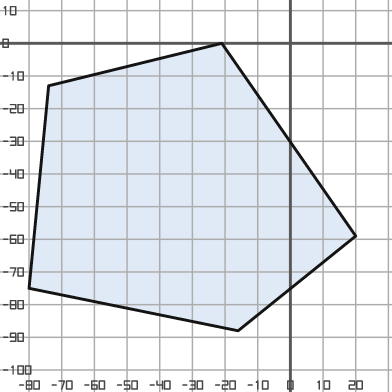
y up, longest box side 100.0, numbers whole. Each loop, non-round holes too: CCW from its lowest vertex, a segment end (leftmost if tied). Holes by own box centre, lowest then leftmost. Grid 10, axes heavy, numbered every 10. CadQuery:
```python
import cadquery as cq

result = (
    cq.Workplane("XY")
    .moveTo(-16.0, -88.0)
    .lineTo(20.0, -59.0)
    .lineTo(-21.0, 0.0)
    .lineTo(-74.0, -13.0)
    .lineTo(-80.0, -75.0)
    .close()
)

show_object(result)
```